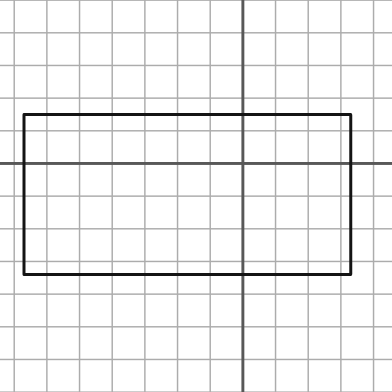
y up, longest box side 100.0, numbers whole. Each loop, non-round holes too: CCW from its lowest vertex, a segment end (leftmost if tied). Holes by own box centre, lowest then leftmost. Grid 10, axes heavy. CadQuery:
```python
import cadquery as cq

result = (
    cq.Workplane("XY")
    .moveTo(-67.0, -34.0)
    .lineTo(33.0, -34.0)
    .lineTo(33.0, 15.0)
    .lineTo(-67.0, 15.0)
    .close()
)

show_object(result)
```